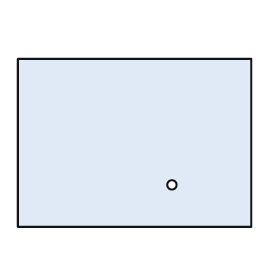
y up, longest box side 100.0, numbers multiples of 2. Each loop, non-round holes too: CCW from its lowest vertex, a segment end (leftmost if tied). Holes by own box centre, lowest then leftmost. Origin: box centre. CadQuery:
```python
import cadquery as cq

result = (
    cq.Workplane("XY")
    .moveTo(-50.0, -36.0)
    .lineTo(50.0, -36.0)
    .lineTo(50.0, 36.0)
    .lineTo(-50.0, 36.0)
    .close()
    .moveTo(16.0, -18.0)
    .circle(2.0)
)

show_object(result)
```